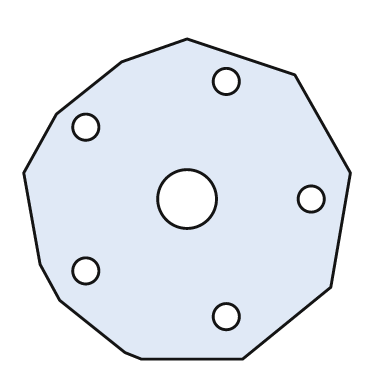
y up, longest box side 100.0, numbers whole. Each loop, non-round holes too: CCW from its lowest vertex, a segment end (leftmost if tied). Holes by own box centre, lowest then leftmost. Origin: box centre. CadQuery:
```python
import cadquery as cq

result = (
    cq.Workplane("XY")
    .moveTo(-14.0, -49.0)
    .lineTo(17.0, -49.0)
    .lineTo(44.0, -27.0)
    .lineTo(50.0, 8.0)
    .lineTo(33.0, 38.0)
    .lineTo(0.0, 49.0)
    .lineTo(-20.0, 42.0)
    .lineTo(-40.0, 26.0)
    .lineTo(-50.0, 8.0)
    .lineTo(-45.0, -20.0)
    .lineTo(-39.0, -31.0)
    .lineTo(-19.0, -47.0)
    .close()
    .moveTo(12.0, -36.0)
    .circle(4.0)
    .moveTo(-31.0, -22.0)
    .circle(4.0)
    .moveTo(0.0, 0.0)
    .circle(9.0)
    .moveTo(38.0, 0.0)
    .circle(4.0)
    .moveTo(-31.0, 22.0)
    .circle(4.0)
    .moveTo(12.0, 36.0)
    .circle(4.0)
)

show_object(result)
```